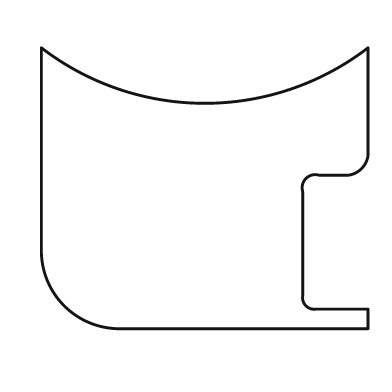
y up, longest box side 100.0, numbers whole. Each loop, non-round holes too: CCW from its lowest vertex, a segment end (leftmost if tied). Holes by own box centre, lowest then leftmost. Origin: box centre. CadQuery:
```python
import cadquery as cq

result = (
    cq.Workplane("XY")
    .moveTo(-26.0, -43.0)
    .lineTo(50.0, -43.0)
    .lineTo(50.0, -37.0)
    .lineTo(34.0, -37.0)
    .threePointArc((31.0, -36.0), (30.0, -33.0))
    .lineTo(30.0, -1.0)
    .threePointArc((31.0, 3.0), (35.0, 4.0))
    .lineTo(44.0, 4.0)
    .threePointArc((48.0, 6.0), (50.0, 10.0))
    .lineTo(50.0, 43.0)
    .threePointArc((0.0, 26.0), (-50.0, 43.0))
    .lineTo(-50.0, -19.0)
    .threePointArc((-43.0, -36.0), (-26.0, -43.0))
    .close()
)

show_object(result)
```